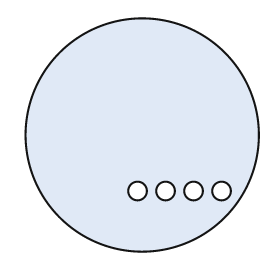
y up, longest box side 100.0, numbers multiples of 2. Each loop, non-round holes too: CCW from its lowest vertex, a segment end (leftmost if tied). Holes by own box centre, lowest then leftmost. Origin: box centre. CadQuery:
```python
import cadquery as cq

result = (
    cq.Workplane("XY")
    .moveTo(0.0, 0.0)
    .circle(50.0)
    .moveTo(-2.0, -24.0)
    .circle(4.0)
    .moveTo(10.0, -24.0)
    .circle(4.0)
    .moveTo(22.0, -24.0)
    .circle(4.0)
    .moveTo(34.0, -24.0)
    .circle(4.0)
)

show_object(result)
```